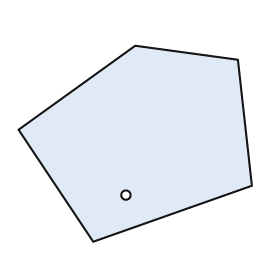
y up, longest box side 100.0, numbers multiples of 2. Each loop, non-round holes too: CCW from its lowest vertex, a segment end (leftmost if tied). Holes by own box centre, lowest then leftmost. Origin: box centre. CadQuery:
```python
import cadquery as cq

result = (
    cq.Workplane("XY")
    .moveTo(-18.0, -42.0)
    .lineTo(50.0, -18.0)
    .lineTo(44.0, 36.0)
    .lineTo(0.0, 42.0)
    .lineTo(-50.0, 6.0)
    .close()
    .moveTo(-4.0, -22.0)
    .circle(2.0)
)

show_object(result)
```